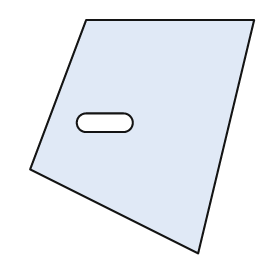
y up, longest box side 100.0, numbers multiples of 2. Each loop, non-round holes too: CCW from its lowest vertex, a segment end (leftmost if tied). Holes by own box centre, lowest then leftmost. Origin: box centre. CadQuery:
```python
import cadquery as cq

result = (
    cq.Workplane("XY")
    .moveTo(24.0, -50.0)
    .lineTo(48.0, 50.0)
    .lineTo(-24.0, 50.0)
    .lineTo(-48.0, -14.0)
    .close()
    .moveTo(-24.0, 2.0)
    .lineTo(-8.0, 2.0)
    .threePointArc((-4.0, 6.0), (-8.0, 10.0))
    .lineTo(-24.0, 10.0)
    .threePointArc((-28.0, 6.0), (-24.0, 2.0))
    .close()
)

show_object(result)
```